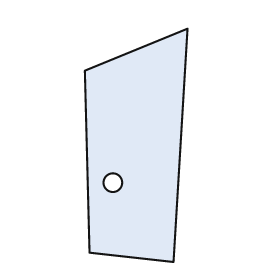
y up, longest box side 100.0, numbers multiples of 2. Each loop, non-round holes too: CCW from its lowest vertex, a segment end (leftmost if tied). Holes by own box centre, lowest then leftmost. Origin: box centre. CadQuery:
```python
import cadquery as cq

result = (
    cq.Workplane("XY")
    .moveTo(16.0, -50.0)
    .lineTo(22.0, 50.0)
    .lineTo(-22.0, 32.0)
    .lineTo(-20.0, -46.0)
    .close()
    .moveTo(-10.0, -16.0)
    .circle(4.0)
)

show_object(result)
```